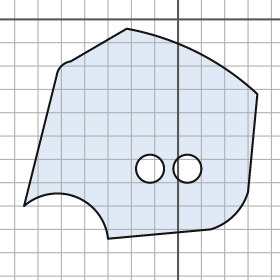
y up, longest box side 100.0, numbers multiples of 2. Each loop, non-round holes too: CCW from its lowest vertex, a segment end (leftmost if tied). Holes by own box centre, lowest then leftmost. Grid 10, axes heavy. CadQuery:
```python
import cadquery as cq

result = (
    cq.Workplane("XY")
    .moveTo(-30.0, -94.0)
    .lineTo(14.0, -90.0)
    .threePointArc((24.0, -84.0), (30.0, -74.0))
    .lineTo(34.0, -32.0)
    .threePointArc((8.0, -14.0), (-22.0, -4.0))
    .lineTo(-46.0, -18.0)
    .threePointArc((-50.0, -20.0), (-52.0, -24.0))
    .lineTo(-66.0, -80.0)
    .threePointArc((-44.0, -76.0), (-30.0, -94.0))
    .close()
    .moveTo(-12.0, -64.0)
    .circle(6.0)
    .moveTo(4.0, -64.0)
    .circle(6.0)
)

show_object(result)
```